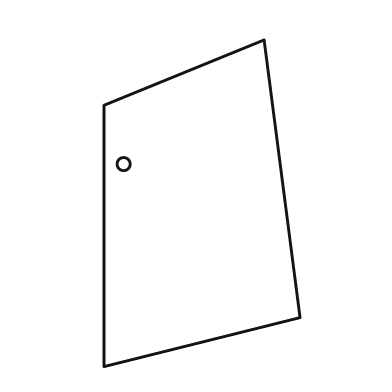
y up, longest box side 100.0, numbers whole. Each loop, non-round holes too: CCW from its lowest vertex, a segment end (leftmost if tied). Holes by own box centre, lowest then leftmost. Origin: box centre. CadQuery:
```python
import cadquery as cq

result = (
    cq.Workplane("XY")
    .moveTo(-30.0, -50.0)
    .lineTo(30.0, -35.0)
    .lineTo(19.0, 50.0)
    .lineTo(-30.0, 30.0)
    .close()
    .moveTo(-24.0, 12.0)
    .circle(2.0)
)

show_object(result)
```